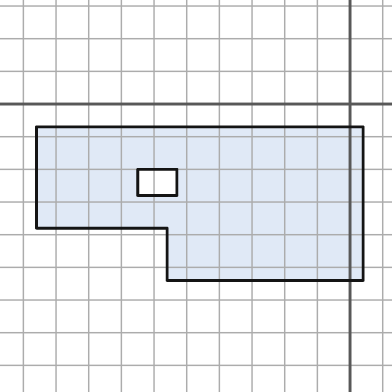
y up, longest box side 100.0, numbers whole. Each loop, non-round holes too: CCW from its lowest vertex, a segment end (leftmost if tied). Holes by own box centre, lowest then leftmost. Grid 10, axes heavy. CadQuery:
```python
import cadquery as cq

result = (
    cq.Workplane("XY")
    .moveTo(-56.0, -54.0)
    .lineTo(4.0, -54.0)
    .lineTo(4.0, -7.0)
    .lineTo(-96.0, -7.0)
    .lineTo(-96.0, -38.0)
    .lineTo(-56.0, -38.0)
    .close()
    .moveTo(-65.0, -28.0)
    .lineTo(-53.0, -28.0)
    .lineTo(-53.0, -20.0)
    .lineTo(-65.0, -20.0)
    .close()
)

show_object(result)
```